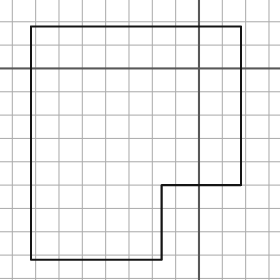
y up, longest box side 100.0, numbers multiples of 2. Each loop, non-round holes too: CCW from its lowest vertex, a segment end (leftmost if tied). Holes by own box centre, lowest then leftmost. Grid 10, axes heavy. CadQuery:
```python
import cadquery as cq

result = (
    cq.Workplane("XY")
    .moveTo(-72.0, -82.0)
    .lineTo(-16.0, -82.0)
    .lineTo(-16.0, -50.0)
    .lineTo(18.0, -50.0)
    .lineTo(18.0, 18.0)
    .lineTo(-72.0, 18.0)
    .close()
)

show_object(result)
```